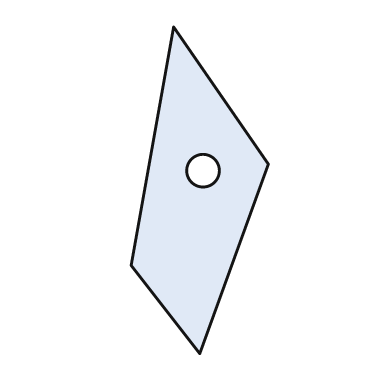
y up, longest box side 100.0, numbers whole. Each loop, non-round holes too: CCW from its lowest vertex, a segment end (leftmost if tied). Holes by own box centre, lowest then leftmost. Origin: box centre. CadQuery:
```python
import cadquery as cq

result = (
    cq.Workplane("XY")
    .moveTo(0.0, -50.0)
    .lineTo(21.0, 8.0)
    .lineTo(-8.0, 50.0)
    .lineTo(-21.0, -23.0)
    .close()
    .moveTo(1.0, 6.0)
    .circle(5.0)
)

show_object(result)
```